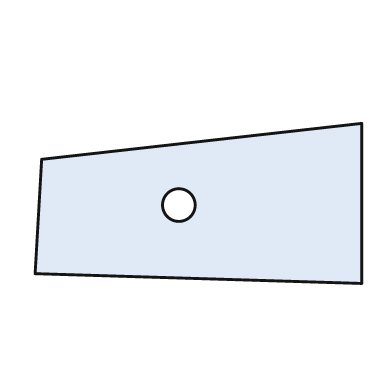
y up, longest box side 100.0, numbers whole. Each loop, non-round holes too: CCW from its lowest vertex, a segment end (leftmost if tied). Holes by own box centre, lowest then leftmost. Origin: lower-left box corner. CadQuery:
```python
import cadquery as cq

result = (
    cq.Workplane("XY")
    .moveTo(100.0, 0.0)
    .lineTo(100.0, 49.0)
    .lineTo(2.0, 38.0)
    .lineTo(0.0, 3.0)
    .close()
    .moveTo(44.0, 24.0)
    .circle(5.0)
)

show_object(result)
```